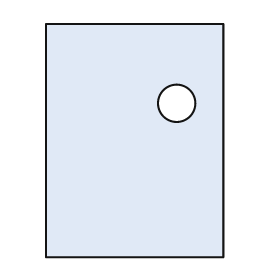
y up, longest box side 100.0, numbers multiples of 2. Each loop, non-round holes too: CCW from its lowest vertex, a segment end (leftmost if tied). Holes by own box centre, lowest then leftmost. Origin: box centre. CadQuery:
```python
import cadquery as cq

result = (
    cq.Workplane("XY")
    .moveTo(-38.0, -50.0)
    .lineTo(38.0, -50.0)
    .lineTo(38.0, 50.0)
    .lineTo(-38.0, 50.0)
    .close()
    .moveTo(18.0, 16.0)
    .circle(8.0)
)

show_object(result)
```